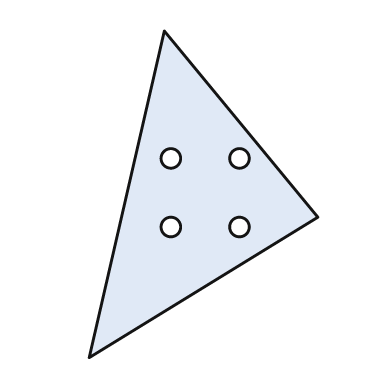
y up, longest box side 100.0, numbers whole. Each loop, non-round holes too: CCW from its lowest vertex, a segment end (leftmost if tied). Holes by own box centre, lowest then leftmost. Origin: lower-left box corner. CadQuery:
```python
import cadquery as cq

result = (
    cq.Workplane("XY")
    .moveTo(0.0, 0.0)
    .lineTo(70.0, 43.0)
    .lineTo(23.0, 100.0)
    .close()
    .moveTo(25.0, 40.0)
    .circle(3.0)
    .moveTo(46.0, 40.0)
    .circle(3.0)
    .moveTo(25.0, 61.0)
    .circle(3.0)
    .moveTo(46.0, 61.0)
    .circle(3.0)
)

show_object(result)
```